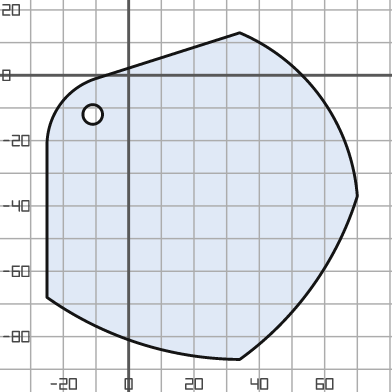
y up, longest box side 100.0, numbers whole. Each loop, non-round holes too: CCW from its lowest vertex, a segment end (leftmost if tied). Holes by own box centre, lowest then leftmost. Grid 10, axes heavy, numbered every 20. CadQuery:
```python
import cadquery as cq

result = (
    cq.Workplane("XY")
    .moveTo(34.0, -87.0)
    .threePointArc((56.0, -65.0), (70.0, -37.0))
    .threePointArc((59.0, -7.0), (34.0, 13.0))
    .lineTo(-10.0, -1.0)
    .threePointArc((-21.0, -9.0), (-25.0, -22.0))
    .lineTo(-25.0, -68.0)
    .threePointArc((3.0, -82.0), (34.0, -87.0))
    .close()
    .moveTo(-11.0, -12.0)
    .circle(3.0)
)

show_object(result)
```